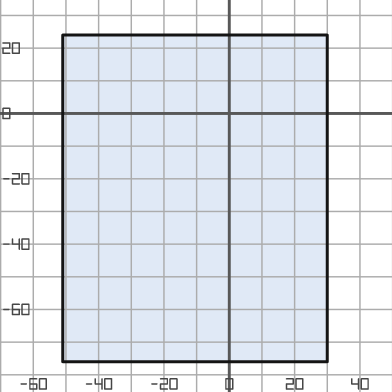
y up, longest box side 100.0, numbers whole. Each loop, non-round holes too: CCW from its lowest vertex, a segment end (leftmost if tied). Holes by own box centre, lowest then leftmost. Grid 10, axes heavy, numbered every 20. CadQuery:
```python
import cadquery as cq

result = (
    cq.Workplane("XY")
    .moveTo(-51.0, -76.0)
    .lineTo(30.0, -76.0)
    .lineTo(30.0, 24.0)
    .lineTo(-51.0, 24.0)
    .close()
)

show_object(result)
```